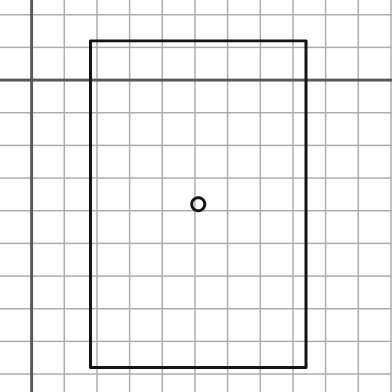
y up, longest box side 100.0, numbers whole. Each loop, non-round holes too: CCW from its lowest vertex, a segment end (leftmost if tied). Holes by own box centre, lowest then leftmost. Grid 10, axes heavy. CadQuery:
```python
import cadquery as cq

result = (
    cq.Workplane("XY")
    .moveTo(18.0, -88.0)
    .lineTo(84.0, -88.0)
    .lineTo(84.0, 12.0)
    .lineTo(18.0, 12.0)
    .close()
    .moveTo(51.0, -38.0)
    .circle(2.0)
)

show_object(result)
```